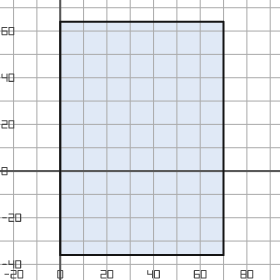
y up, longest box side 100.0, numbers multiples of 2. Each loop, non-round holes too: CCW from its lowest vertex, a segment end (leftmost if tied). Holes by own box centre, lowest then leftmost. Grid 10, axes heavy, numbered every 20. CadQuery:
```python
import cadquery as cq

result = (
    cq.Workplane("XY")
    .moveTo(0.0, -36.0)
    .lineTo(70.0, -36.0)
    .lineTo(70.0, 64.0)
    .lineTo(0.0, 64.0)
    .close()
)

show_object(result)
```